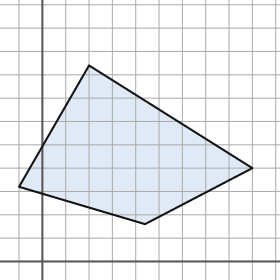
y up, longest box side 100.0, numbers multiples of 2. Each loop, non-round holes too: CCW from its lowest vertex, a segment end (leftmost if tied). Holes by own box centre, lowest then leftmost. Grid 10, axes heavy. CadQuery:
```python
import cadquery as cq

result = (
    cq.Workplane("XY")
    .moveTo(44.0, 16.0)
    .lineTo(90.0, 40.0)
    .lineTo(20.0, 84.0)
    .lineTo(-10.0, 32.0)
    .close()
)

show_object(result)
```